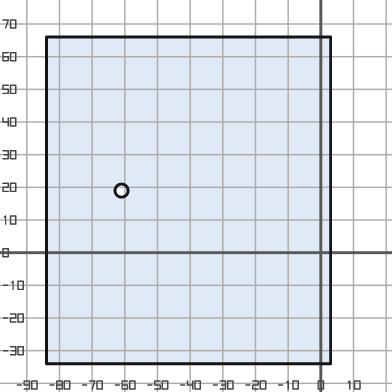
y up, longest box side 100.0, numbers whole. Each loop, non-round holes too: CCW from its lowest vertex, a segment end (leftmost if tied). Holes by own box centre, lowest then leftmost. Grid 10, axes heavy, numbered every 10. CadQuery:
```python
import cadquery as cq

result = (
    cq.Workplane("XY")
    .moveTo(-84.0, -34.0)
    .lineTo(3.0, -34.0)
    .lineTo(3.0, 66.0)
    .lineTo(-84.0, 66.0)
    .close()
    .moveTo(-61.0, 19.0)
    .circle(2.0)
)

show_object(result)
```